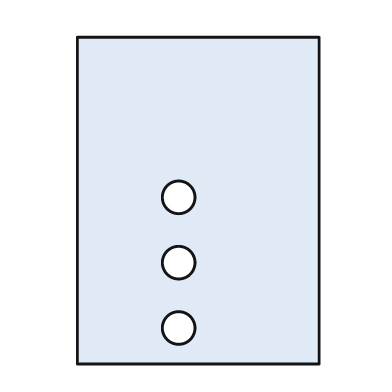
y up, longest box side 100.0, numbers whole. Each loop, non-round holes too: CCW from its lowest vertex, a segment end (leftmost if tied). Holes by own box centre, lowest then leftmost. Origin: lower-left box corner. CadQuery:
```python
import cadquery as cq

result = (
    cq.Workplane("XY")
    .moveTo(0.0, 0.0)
    .lineTo(74.0, 0.0)
    .lineTo(74.0, 100.0)
    .lineTo(0.0, 100.0)
    .close()
    .moveTo(31.0, 11.0)
    .circle(5.0)
    .moveTo(31.0, 31.0)
    .circle(5.0)
    .moveTo(31.0, 51.0)
    .circle(5.0)
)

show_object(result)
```